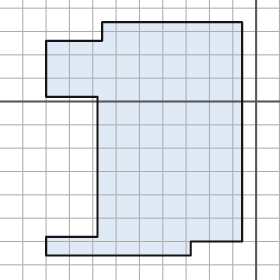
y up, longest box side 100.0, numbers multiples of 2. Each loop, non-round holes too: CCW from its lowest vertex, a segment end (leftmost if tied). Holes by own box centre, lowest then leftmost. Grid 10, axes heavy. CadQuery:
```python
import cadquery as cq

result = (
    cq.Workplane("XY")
    .moveTo(-90.0, -66.0)
    .lineTo(-28.0, -66.0)
    .lineTo(-28.0, -60.0)
    .lineTo(-6.0, -60.0)
    .lineTo(-6.0, 34.0)
    .lineTo(-66.0, 34.0)
    .lineTo(-66.0, 26.0)
    .lineTo(-90.0, 26.0)
    .lineTo(-90.0, 2.0)
    .lineTo(-68.0, 2.0)
    .lineTo(-68.0, -58.0)
    .lineTo(-90.0, -58.0)
    .close()
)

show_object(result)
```